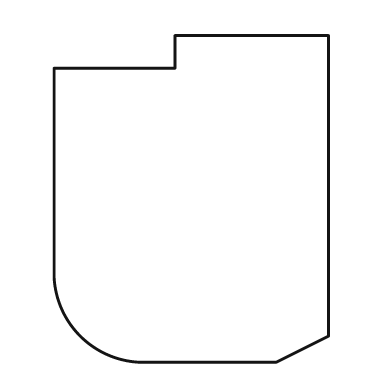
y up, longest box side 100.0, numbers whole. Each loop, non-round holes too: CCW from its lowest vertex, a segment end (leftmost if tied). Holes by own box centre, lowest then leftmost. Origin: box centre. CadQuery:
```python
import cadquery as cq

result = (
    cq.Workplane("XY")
    .moveTo(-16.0, -50.0)
    .lineTo(26.0, -50.0)
    .lineTo(42.0, -42.0)
    .lineTo(42.0, 50.0)
    .lineTo(-5.0, 50.0)
    .lineTo(-5.0, 40.0)
    .lineTo(-42.0, 40.0)
    .lineTo(-42.0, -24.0)
    .threePointArc((-34.0, -42.0), (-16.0, -50.0))
    .close()
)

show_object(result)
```